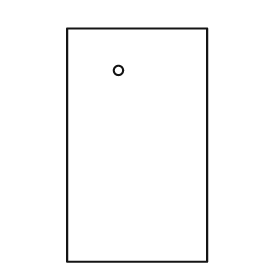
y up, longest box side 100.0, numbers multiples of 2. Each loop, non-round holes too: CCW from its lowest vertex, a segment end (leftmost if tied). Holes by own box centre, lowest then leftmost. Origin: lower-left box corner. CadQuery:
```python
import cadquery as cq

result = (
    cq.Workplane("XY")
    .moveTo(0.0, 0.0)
    .lineTo(60.0, 0.0)
    .lineTo(60.0, 100.0)
    .lineTo(0.0, 100.0)
    .close()
    .moveTo(22.0, 82.0)
    .circle(2.0)
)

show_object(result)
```